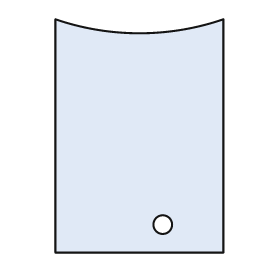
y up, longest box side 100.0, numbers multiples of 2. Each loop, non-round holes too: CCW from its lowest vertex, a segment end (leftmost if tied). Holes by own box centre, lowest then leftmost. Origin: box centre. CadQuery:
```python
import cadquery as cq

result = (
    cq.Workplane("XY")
    .moveTo(-36.0, -50.0)
    .lineTo(36.0, -50.0)
    .lineTo(36.0, 50.0)
    .threePointArc((0.0, 44.0), (-36.0, 50.0))
    .close()
    .moveTo(10.0, -38.0)
    .circle(4.0)
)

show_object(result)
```